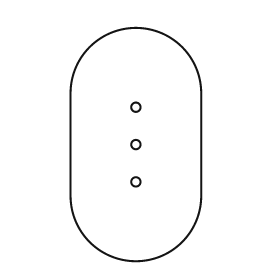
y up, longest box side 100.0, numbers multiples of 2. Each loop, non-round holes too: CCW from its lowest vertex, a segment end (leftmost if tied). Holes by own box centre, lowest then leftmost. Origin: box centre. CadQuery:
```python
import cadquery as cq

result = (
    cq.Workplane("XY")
    .moveTo(-28.0, -22.0)
    .threePointArc((0.0, -50.0), (28.0, -22.0))
    .lineTo(28.0, 22.0)
    .threePointArc((0.0, 50.0), (-28.0, 22.0))
    .close()
    .moveTo(0.0, -16.0)
    .circle(2.0)
    .moveTo(0.0, 0.0)
    .circle(2.0)
    .moveTo(0.0, 16.0)
    .circle(2.0)
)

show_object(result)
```